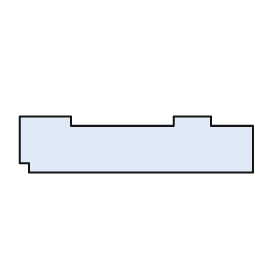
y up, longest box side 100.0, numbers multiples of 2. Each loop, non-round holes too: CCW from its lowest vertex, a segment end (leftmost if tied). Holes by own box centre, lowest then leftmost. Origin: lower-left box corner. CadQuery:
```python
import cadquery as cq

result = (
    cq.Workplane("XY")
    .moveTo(4.0, 0.0)
    .lineTo(100.0, 0.0)
    .lineTo(100.0, 20.0)
    .lineTo(82.0, 20.0)
    .lineTo(82.0, 24.0)
    .lineTo(66.0, 24.0)
    .lineTo(66.0, 20.0)
    .lineTo(22.0, 20.0)
    .lineTo(22.0, 24.0)
    .lineTo(0.0, 24.0)
    .lineTo(0.0, 4.0)
    .lineTo(4.0, 4.0)
    .close()
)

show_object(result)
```